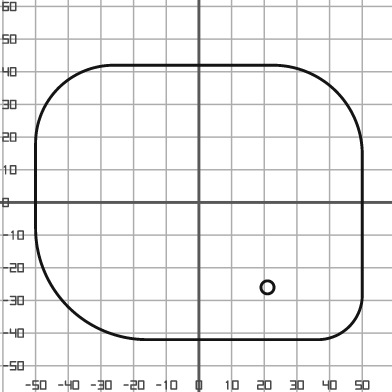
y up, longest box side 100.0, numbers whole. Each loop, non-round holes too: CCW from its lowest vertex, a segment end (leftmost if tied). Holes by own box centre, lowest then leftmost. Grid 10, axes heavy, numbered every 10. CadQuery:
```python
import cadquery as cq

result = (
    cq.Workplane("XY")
    .moveTo(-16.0, -42.0)
    .lineTo(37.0, -42.0)
    .threePointArc((46.0, -38.0), (50.0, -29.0))
    .lineTo(50.0, 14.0)
    .threePointArc((42.0, 34.0), (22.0, 42.0))
    .lineTo(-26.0, 42.0)
    .threePointArc((-43.0, 35.0), (-50.0, 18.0))
    .lineTo(-50.0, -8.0)
    .threePointArc((-40.0, -32.0), (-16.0, -42.0))
    .close()
    .moveTo(21.0, -26.0)
    .circle(2.0)
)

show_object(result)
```